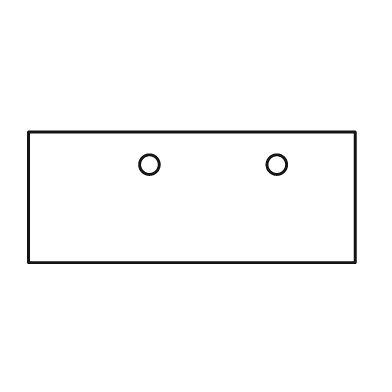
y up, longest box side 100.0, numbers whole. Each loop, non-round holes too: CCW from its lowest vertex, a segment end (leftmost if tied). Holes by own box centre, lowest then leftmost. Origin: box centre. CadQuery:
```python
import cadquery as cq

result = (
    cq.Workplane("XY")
    .moveTo(-50.0, -20.0)
    .lineTo(50.0, -20.0)
    .lineTo(50.0, 20.0)
    .lineTo(-50.0, 20.0)
    .close()
    .moveTo(-13.0, 10.0)
    .circle(3.0)
    .moveTo(26.0, 10.0)
    .circle(3.0)
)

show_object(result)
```